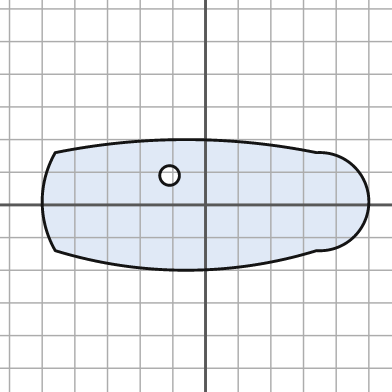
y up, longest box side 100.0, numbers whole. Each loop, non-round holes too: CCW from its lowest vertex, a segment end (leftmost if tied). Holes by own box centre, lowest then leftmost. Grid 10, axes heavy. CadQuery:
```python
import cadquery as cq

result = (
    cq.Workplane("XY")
    .moveTo(-46.0, -14.0)
    .threePointArc((-6.0, -20.0), (34.0, -14.0))
    .threePointArc((50.0, 1.0), (34.0, 16.0))
    .threePointArc((-6.0, 20.0), (-46.0, 16.0))
    .threePointArc((-50.0, 1.0), (-46.0, -14.0))
    .close()
    .moveTo(-11.0, 9.0)
    .circle(3.0)
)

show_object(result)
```